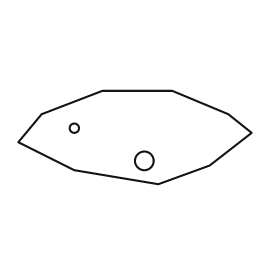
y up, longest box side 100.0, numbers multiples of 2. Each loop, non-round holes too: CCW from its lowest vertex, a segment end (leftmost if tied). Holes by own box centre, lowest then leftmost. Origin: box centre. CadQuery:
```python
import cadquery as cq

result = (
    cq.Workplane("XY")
    .moveTo(10.0, -20.0)
    .lineTo(32.0, -12.0)
    .lineTo(50.0, 2.0)
    .lineTo(40.0, 10.0)
    .lineTo(16.0, 20.0)
    .lineTo(-14.0, 20.0)
    .lineTo(-40.0, 10.0)
    .lineTo(-50.0, -2.0)
    .lineTo(-26.0, -14.0)
    .close()
    .moveTo(4.0, -10.0)
    .circle(4.0)
    .moveTo(-26.0, 4.0)
    .circle(2.0)
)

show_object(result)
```